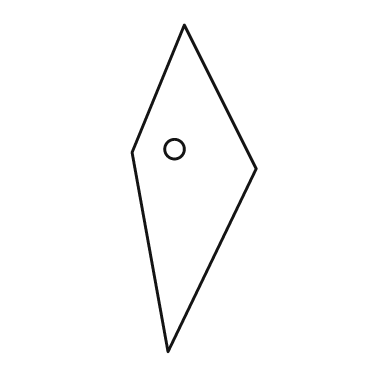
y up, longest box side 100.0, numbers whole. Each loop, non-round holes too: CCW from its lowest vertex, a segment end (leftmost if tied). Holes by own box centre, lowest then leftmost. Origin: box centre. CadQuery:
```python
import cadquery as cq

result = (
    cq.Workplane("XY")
    .moveTo(-8.0, -50.0)
    .lineTo(19.0, 6.0)
    .lineTo(-3.0, 50.0)
    .lineTo(-19.0, 11.0)
    .close()
    .moveTo(-6.0, 12.0)
    .circle(3.0)
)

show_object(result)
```